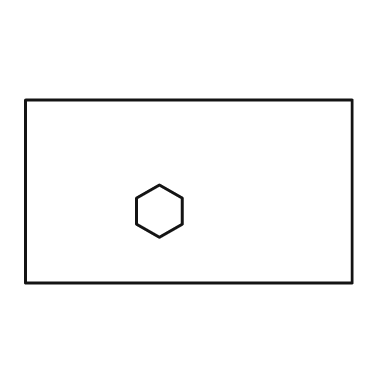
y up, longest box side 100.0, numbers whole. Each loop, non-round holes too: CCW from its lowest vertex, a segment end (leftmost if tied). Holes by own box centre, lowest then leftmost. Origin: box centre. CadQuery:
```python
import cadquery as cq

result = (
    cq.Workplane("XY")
    .moveTo(-50.0, -28.0)
    .lineTo(50.0, -28.0)
    .lineTo(50.0, 28.0)
    .lineTo(-50.0, 28.0)
    .close()
    .moveTo(-9.0, -14.0)
    .lineTo(-2.0, -10.0)
    .lineTo(-2.0, -2.0)
    .lineTo(-9.0, 2.0)
    .lineTo(-16.0, -2.0)
    .lineTo(-16.0, -10.0)
    .close()
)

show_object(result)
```